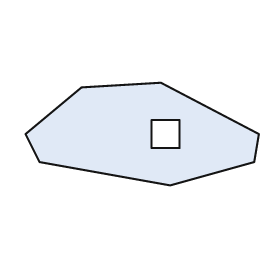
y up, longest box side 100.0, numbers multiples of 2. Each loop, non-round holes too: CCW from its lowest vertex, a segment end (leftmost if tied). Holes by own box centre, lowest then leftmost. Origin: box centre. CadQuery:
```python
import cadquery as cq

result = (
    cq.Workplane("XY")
    .moveTo(12.0, -22.0)
    .lineTo(48.0, -12.0)
    .lineTo(50.0, 0.0)
    .lineTo(8.0, 22.0)
    .lineTo(-26.0, 20.0)
    .lineTo(-50.0, 0.0)
    .lineTo(-44.0, -12.0)
    .close()
    .moveTo(4.0, -6.0)
    .lineTo(16.0, -6.0)
    .lineTo(16.0, 6.0)
    .lineTo(4.0, 6.0)
    .close()
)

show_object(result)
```